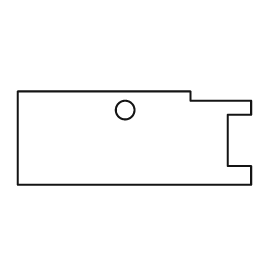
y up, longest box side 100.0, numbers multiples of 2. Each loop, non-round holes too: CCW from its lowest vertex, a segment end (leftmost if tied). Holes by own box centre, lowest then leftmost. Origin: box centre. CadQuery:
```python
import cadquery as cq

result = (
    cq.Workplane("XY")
    .moveTo(-50.0, -20.0)
    .lineTo(50.0, -20.0)
    .lineTo(50.0, -12.0)
    .lineTo(40.0, -12.0)
    .lineTo(40.0, 10.0)
    .lineTo(50.0, 10.0)
    .lineTo(50.0, 16.0)
    .lineTo(24.0, 16.0)
    .lineTo(24.0, 20.0)
    .lineTo(-50.0, 20.0)
    .close()
    .moveTo(-4.0, 12.0)
    .circle(4.0)
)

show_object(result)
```